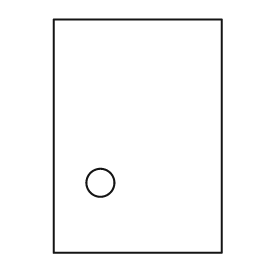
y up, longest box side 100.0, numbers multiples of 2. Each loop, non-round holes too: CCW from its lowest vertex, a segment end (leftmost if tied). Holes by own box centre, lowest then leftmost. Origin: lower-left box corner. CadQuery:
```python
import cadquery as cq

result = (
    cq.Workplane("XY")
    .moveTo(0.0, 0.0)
    .lineTo(72.0, 0.0)
    .lineTo(72.0, 100.0)
    .lineTo(0.0, 100.0)
    .close()
    .moveTo(20.0, 30.0)
    .circle(6.0)
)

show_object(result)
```